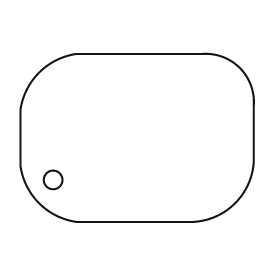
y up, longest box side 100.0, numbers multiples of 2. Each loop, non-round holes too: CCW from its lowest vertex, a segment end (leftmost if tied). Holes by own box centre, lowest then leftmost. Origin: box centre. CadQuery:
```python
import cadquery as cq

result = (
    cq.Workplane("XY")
    .moveTo(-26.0, -36.0)
    .lineTo(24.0, -36.0)
    .threePointArc((42.0, -28.0), (50.0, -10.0))
    .lineTo(50.0, 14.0)
    .threePointArc((44.0, 30.0), (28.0, 36.0))
    .lineTo(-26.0, 36.0)
    .threePointArc((-42.0, 28.0), (-50.0, 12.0))
    .lineTo(-50.0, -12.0)
    .threePointArc((-42.0, -28.0), (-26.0, -36.0))
    .close()
    .moveTo(-36.0, -18.0)
    .circle(4.0)
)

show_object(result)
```